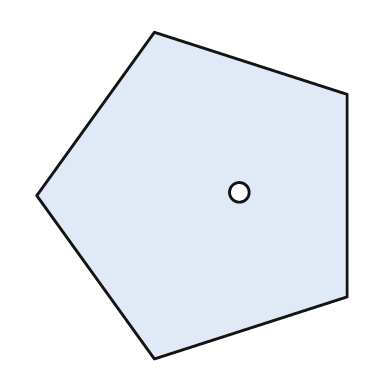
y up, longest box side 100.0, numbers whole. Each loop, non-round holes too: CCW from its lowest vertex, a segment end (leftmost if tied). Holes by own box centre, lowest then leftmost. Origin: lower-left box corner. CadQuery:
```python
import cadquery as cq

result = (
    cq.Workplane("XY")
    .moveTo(36.0, 0.0)
    .lineTo(95.0, 19.0)
    .lineTo(95.0, 81.0)
    .lineTo(36.0, 100.0)
    .lineTo(0.0, 50.0)
    .close()
    .moveTo(62.0, 51.0)
    .circle(3.0)
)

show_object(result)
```